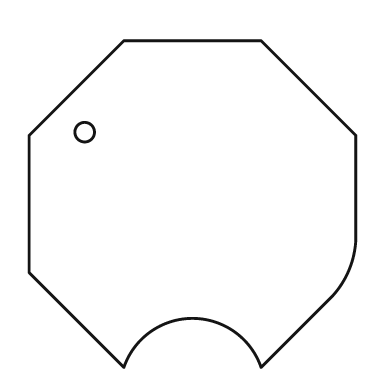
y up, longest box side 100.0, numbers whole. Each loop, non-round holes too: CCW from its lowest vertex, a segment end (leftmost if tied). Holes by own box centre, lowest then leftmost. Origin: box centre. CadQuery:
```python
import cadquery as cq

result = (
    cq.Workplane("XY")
    .moveTo(-21.0, -50.0)
    .threePointArc((0.0, -35.0), (21.0, -50.0))
    .lineTo(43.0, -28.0)
    .threePointArc((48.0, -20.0), (50.0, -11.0))
    .lineTo(50.0, 21.0)
    .lineTo(21.0, 50.0)
    .lineTo(-21.0, 50.0)
    .lineTo(-50.0, 21.0)
    .lineTo(-50.0, -21.0)
    .close()
    .moveTo(-33.0, 22.0)
    .circle(3.0)
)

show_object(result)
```